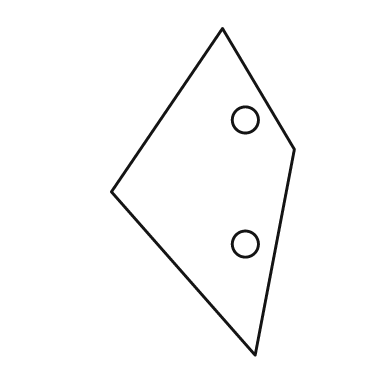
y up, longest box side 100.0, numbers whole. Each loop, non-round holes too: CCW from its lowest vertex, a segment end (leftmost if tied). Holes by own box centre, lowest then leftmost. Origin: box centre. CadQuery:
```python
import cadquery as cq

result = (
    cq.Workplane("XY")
    .moveTo(16.0, -50.0)
    .lineTo(28.0, 13.0)
    .lineTo(6.0, 50.0)
    .lineTo(-28.0, 0.0)
    .close()
    .moveTo(13.0, -16.0)
    .circle(4.0)
    .moveTo(13.0, 22.0)
    .circle(4.0)
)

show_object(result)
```